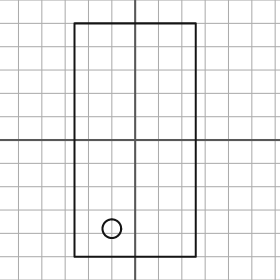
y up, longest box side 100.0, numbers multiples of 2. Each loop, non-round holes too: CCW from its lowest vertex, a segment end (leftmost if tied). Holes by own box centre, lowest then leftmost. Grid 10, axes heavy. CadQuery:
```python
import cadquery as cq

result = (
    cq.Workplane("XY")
    .moveTo(-26.0, -50.0)
    .lineTo(26.0, -50.0)
    .lineTo(26.0, 50.0)
    .lineTo(-26.0, 50.0)
    .close()
    .moveTo(-10.0, -38.0)
    .circle(4.0)
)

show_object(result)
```